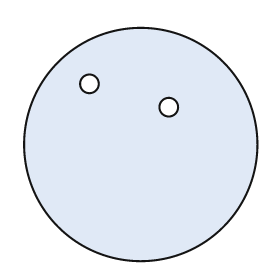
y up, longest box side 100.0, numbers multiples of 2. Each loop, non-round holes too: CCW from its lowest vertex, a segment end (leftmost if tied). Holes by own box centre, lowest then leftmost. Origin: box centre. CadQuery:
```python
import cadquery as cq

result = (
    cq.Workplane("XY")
    .moveTo(0.0, 0.0)
    .circle(50.0)
    .moveTo(12.0, 16.0)
    .circle(4.0)
    .moveTo(-22.0, 26.0)
    .circle(4.0)
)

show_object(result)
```